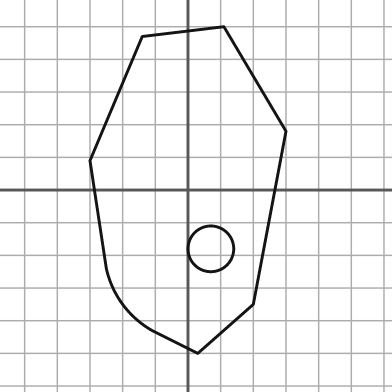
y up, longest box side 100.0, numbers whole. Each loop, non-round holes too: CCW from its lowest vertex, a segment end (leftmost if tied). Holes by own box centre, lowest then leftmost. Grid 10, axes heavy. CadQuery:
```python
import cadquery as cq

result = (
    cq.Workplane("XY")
    .moveTo(3.0, -50.0)
    .lineTo(20.0, -35.0)
    .lineTo(30.0, 18.0)
    .lineTo(11.0, 50.0)
    .lineTo(-14.0, 47.0)
    .lineTo(-30.0, 9.0)
    .lineTo(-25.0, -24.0)
    .threePointArc((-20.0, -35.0), (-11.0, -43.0))
    .close()
    .moveTo(7.0, -18.0)
    .circle(7.0)
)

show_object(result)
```